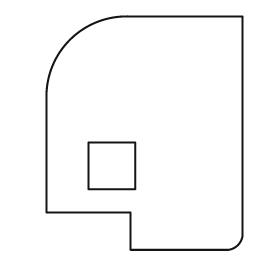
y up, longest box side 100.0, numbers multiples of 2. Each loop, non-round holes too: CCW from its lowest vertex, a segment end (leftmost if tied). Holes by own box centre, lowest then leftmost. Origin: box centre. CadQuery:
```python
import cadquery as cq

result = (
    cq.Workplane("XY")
    .moveTo(-6.0, -50.0)
    .lineTo(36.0, -50.0)
    .threePointArc((40.0, -48.0), (42.0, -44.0))
    .lineTo(42.0, 50.0)
    .lineTo(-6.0, 50.0)
    .threePointArc((-32.0, 40.0), (-42.0, 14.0))
    .lineTo(-42.0, -34.0)
    .lineTo(-6.0, -34.0)
    .close()
    .moveTo(-24.0, -24.0)
    .lineTo(-4.0, -24.0)
    .lineTo(-4.0, -4.0)
    .lineTo(-24.0, -4.0)
    .close()
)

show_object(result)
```